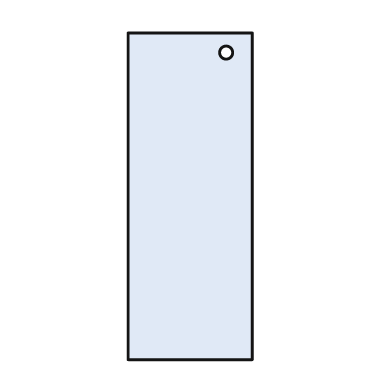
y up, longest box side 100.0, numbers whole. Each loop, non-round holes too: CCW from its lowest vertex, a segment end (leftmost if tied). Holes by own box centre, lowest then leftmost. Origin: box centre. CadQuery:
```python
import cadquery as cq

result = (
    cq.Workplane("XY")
    .moveTo(-19.0, -50.0)
    .lineTo(19.0, -50.0)
    .lineTo(19.0, 50.0)
    .lineTo(-19.0, 50.0)
    .close()
    .moveTo(11.0, 44.0)
    .circle(2.0)
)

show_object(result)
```